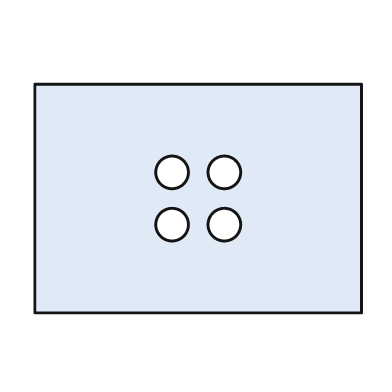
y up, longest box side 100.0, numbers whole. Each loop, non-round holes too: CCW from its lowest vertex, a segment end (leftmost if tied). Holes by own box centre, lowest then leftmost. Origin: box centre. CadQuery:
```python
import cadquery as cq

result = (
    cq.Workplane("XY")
    .moveTo(-50.0, -35.0)
    .lineTo(50.0, -35.0)
    .lineTo(50.0, 35.0)
    .lineTo(-50.0, 35.0)
    .close()
    .moveTo(-8.0, -8.0)
    .circle(5.0)
    .moveTo(8.0, -8.0)
    .circle(5.0)
    .moveTo(-8.0, 8.0)
    .circle(5.0)
    .moveTo(8.0, 8.0)
    .circle(5.0)
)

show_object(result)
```